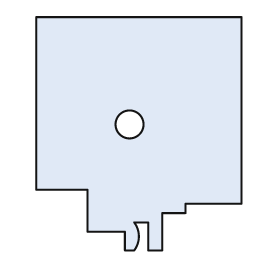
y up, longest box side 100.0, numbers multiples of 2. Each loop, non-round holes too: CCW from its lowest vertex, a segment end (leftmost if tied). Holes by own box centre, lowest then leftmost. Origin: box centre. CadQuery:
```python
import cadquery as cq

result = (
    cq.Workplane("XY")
    .moveTo(-6.0, -50.0)
    .lineTo(-2.0, -50.0)
    .threePointArc((0.0, -44.0), (-2.0, -38.0))
    .lineTo(4.0, -38.0)
    .lineTo(4.0, -50.0)
    .lineTo(10.0, -50.0)
    .lineTo(10.0, -34.0)
    .lineTo(20.0, -34.0)
    .lineTo(20.0, -30.0)
    .lineTo(44.0, -30.0)
    .lineTo(44.0, 50.0)
    .lineTo(-44.0, 50.0)
    .lineTo(-44.0, -24.0)
    .lineTo(-22.0, -24.0)
    .lineTo(-22.0, -42.0)
    .lineTo(-6.0, -42.0)
    .close()
    .moveTo(-4.0, 4.0)
    .circle(6.0)
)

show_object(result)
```